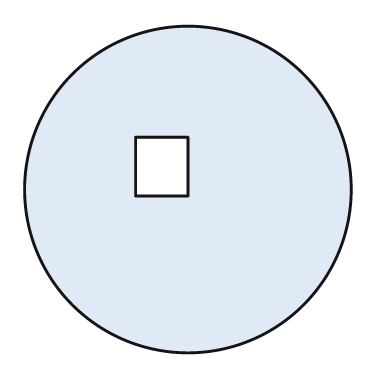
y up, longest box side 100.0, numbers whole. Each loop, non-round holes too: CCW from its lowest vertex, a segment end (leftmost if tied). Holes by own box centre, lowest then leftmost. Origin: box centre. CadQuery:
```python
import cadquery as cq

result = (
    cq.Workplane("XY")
    .moveTo(0.0, 0.0)
    .circle(50.0)
    .moveTo(-16.0, -2.0)
    .lineTo(0.0, -2.0)
    .lineTo(0.0, 16.0)
    .lineTo(-16.0, 16.0)
    .close()
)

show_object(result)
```